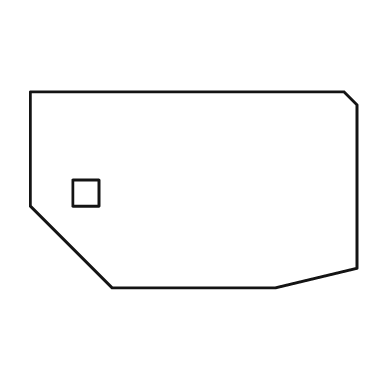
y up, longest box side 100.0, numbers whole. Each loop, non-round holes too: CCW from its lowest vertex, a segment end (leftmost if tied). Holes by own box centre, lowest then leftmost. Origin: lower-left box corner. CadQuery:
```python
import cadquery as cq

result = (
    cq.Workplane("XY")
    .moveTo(25.0, 0.0)
    .lineTo(75.0, 0.0)
    .lineTo(100.0, 6.0)
    .lineTo(100.0, 56.0)
    .lineTo(96.0, 60.0)
    .lineTo(0.0, 60.0)
    .lineTo(0.0, 25.0)
    .close()
    .moveTo(13.0, 25.0)
    .lineTo(21.0, 25.0)
    .lineTo(21.0, 33.0)
    .lineTo(13.0, 33.0)
    .close()
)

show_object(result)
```